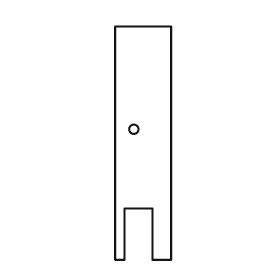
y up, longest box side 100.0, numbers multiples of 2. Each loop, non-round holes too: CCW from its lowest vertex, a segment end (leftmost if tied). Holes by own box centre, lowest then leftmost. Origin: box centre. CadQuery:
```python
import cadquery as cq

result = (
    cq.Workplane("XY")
    .moveTo(-12.0, -50.0)
    .lineTo(-8.0, -50.0)
    .lineTo(-8.0, -28.0)
    .lineTo(4.0, -28.0)
    .lineTo(4.0, -50.0)
    .lineTo(12.0, -50.0)
    .lineTo(12.0, 50.0)
    .lineTo(-12.0, 50.0)
    .close()
    .moveTo(-4.0, 6.0)
    .circle(2.0)
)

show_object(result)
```